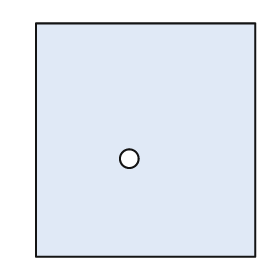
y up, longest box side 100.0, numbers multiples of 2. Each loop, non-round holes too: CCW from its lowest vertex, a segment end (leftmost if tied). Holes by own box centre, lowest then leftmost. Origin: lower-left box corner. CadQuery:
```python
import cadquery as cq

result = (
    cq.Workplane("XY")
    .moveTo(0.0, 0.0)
    .lineTo(94.0, 0.0)
    .lineTo(94.0, 100.0)
    .lineTo(0.0, 100.0)
    .close()
    .moveTo(40.0, 42.0)
    .circle(4.0)
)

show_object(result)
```